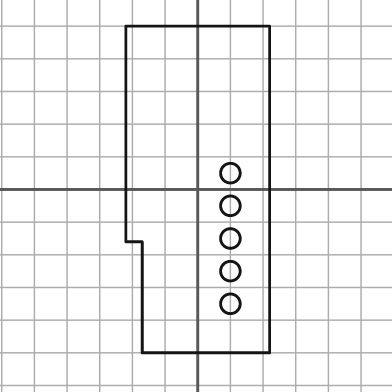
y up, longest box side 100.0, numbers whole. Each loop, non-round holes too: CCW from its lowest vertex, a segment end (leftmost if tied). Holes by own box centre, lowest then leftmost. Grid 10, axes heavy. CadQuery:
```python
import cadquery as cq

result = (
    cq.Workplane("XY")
    .moveTo(-17.0, -50.0)
    .lineTo(22.0, -50.0)
    .lineTo(22.0, 50.0)
    .lineTo(-22.0, 50.0)
    .lineTo(-22.0, -16.0)
    .lineTo(-17.0, -16.0)
    .close()
    .moveTo(10.0, -35.0)
    .circle(3.0)
    .moveTo(10.0, -25.0)
    .circle(3.0)
    .moveTo(10.0, -15.0)
    .circle(3.0)
    .moveTo(10.0, -5.0)
    .circle(3.0)
    .moveTo(10.0, 5.0)
    .circle(3.0)
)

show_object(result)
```